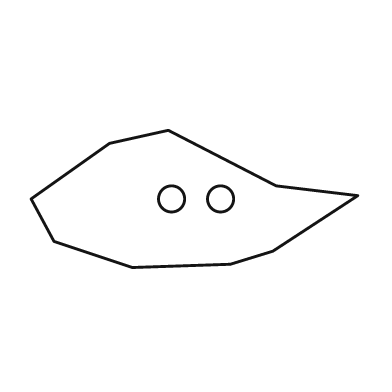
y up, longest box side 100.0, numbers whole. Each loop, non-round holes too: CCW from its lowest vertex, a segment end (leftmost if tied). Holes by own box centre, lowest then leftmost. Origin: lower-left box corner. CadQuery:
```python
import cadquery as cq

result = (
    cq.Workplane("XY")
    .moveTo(31.0, 0.0)
    .lineTo(61.0, 1.0)
    .lineTo(74.0, 5.0)
    .lineTo(100.0, 22.0)
    .lineTo(75.0, 25.0)
    .lineTo(42.0, 42.0)
    .lineTo(24.0, 38.0)
    .lineTo(0.0, 21.0)
    .lineTo(7.0, 8.0)
    .close()
    .moveTo(43.0, 21.0)
    .circle(4.0)
    .moveTo(58.0, 21.0)
    .circle(4.0)
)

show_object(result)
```